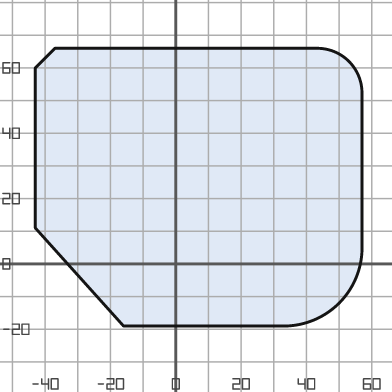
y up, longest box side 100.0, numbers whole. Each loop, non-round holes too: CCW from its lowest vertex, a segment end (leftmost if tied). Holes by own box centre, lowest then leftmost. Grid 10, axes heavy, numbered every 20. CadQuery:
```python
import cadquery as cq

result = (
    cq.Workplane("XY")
    .moveTo(-16.0, -19.0)
    .lineTo(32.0, -19.0)
    .threePointArc((50.0, -12.0), (57.0, 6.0))
    .lineTo(57.0, 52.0)
    .threePointArc((53.0, 62.0), (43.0, 66.0))
    .lineTo(-37.0, 66.0)
    .lineTo(-43.0, 60.0)
    .lineTo(-43.0, 11.0)
    .close()
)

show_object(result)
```